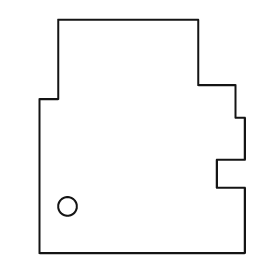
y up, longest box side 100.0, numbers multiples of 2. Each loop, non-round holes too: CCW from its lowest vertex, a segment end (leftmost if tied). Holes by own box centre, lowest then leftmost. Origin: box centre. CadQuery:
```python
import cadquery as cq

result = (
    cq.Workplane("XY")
    .moveTo(-44.0, -50.0)
    .lineTo(44.0, -50.0)
    .lineTo(44.0, -22.0)
    .lineTo(32.0, -22.0)
    .lineTo(32.0, -10.0)
    .lineTo(44.0, -10.0)
    .lineTo(44.0, 8.0)
    .lineTo(40.0, 8.0)
    .lineTo(40.0, 22.0)
    .lineTo(24.0, 22.0)
    .lineTo(24.0, 50.0)
    .lineTo(-36.0, 50.0)
    .lineTo(-36.0, 16.0)
    .lineTo(-44.0, 16.0)
    .close()
    .moveTo(-32.0, -30.0)
    .circle(4.0)
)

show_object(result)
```